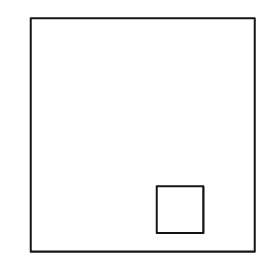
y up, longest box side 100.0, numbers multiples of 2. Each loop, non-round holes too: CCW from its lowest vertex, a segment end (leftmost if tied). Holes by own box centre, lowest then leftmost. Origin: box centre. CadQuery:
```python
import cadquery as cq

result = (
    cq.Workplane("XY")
    .moveTo(-48.0, -50.0)
    .lineTo(48.0, -50.0)
    .lineTo(48.0, 50.0)
    .lineTo(-48.0, 50.0)
    .close()
    .moveTo(6.0, -42.0)
    .lineTo(26.0, -42.0)
    .lineTo(26.0, -22.0)
    .lineTo(6.0, -22.0)
    .close()
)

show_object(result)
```